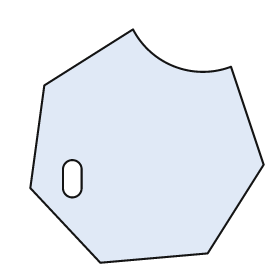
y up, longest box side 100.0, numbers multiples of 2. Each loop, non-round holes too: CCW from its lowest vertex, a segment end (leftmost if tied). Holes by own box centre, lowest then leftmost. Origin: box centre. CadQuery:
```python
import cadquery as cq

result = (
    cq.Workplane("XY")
    .moveTo(-20.0, -50.0)
    .lineTo(26.0, -46.0)
    .lineTo(50.0, -8.0)
    .lineTo(36.0, 34.0)
    .threePointArc((12.0, 34.0), (-6.0, 50.0))
    .lineTo(-44.0, 26.0)
    .lineTo(-50.0, -18.0)
    .close()
    .moveTo(-36.0, -18.0)
    .threePointArc((-32.0, -22.0), (-28.0, -18.0))
    .lineTo(-28.0, -10.0)
    .threePointArc((-32.0, -6.0), (-36.0, -10.0))
    .close()
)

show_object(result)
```